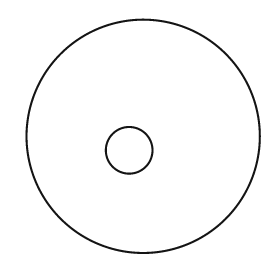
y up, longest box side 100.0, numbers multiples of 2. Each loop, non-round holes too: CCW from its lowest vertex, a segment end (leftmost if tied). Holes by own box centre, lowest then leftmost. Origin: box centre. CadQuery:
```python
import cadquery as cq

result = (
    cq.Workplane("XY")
    .moveTo(0.0, 0.0)
    .circle(50.0)
    .moveTo(-6.0, -6.0)
    .circle(10.0)
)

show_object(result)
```